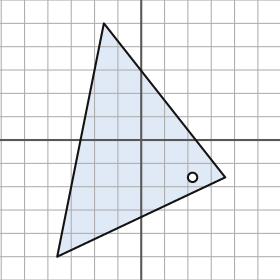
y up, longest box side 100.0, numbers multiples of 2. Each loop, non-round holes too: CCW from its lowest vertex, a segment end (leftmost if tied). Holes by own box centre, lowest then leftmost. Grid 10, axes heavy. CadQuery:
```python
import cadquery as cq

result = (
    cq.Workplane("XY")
    .moveTo(-36.0, -50.0)
    .lineTo(36.0, -16.0)
    .lineTo(-16.0, 50.0)
    .close()
    .moveTo(22.0, -16.0)
    .circle(2.0)
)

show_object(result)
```